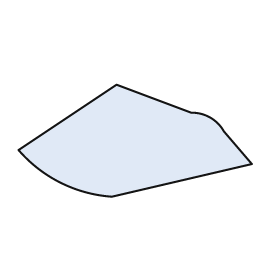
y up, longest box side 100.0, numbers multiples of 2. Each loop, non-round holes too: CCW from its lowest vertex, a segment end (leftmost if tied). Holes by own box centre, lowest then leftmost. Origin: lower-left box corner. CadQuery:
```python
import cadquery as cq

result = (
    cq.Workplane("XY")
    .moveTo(40.0, 0.0)
    .lineTo(100.0, 14.0)
    .lineTo(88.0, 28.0)
    .threePointArc((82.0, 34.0), (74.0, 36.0))
    .lineTo(42.0, 48.0)
    .lineTo(0.0, 20.0)
    .threePointArc((18.0, 6.0), (40.0, 0.0))
    .close()
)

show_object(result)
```